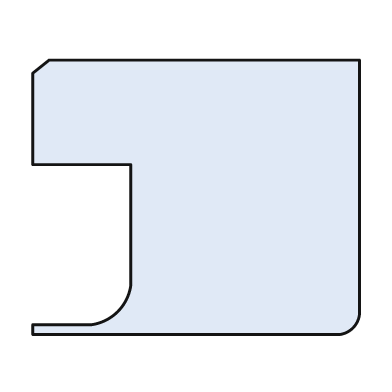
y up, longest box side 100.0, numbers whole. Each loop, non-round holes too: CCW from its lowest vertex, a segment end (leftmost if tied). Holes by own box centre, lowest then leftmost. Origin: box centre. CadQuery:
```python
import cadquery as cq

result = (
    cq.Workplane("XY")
    .moveTo(-50.0, -42.0)
    .lineTo(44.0, -42.0)
    .threePointArc((48.0, -40.0), (50.0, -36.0))
    .lineTo(50.0, 42.0)
    .lineTo(-45.0, 42.0)
    .lineTo(-50.0, 38.0)
    .lineTo(-50.0, 10.0)
    .lineTo(-20.0, 10.0)
    .lineTo(-20.0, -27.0)
    .threePointArc((-24.0, -35.0), (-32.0, -39.0))
    .lineTo(-50.0, -39.0)
    .close()
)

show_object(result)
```